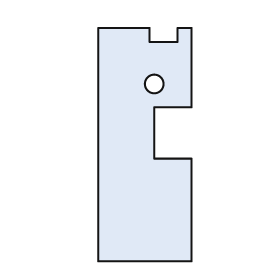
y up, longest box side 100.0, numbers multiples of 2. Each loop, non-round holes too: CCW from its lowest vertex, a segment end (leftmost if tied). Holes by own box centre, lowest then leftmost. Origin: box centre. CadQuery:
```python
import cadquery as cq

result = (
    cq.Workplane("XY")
    .moveTo(-20.0, -50.0)
    .lineTo(20.0, -50.0)
    .lineTo(20.0, -6.0)
    .lineTo(4.0, -6.0)
    .lineTo(4.0, 16.0)
    .lineTo(20.0, 16.0)
    .lineTo(20.0, 50.0)
    .lineTo(14.0, 50.0)
    .lineTo(14.0, 44.0)
    .lineTo(2.0, 44.0)
    .lineTo(2.0, 50.0)
    .lineTo(-20.0, 50.0)
    .close()
    .moveTo(4.0, 26.0)
    .circle(4.0)
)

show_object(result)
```